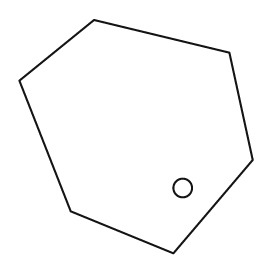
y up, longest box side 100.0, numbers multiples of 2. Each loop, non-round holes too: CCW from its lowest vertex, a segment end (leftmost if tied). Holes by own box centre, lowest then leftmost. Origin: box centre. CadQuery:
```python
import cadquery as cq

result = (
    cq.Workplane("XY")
    .moveTo(16.0, -50.0)
    .lineTo(50.0, -10.0)
    .lineTo(40.0, 36.0)
    .lineTo(-18.0, 50.0)
    .lineTo(-50.0, 24.0)
    .lineTo(-28.0, -32.0)
    .close()
    .moveTo(20.0, -22.0)
    .circle(4.0)
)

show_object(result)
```